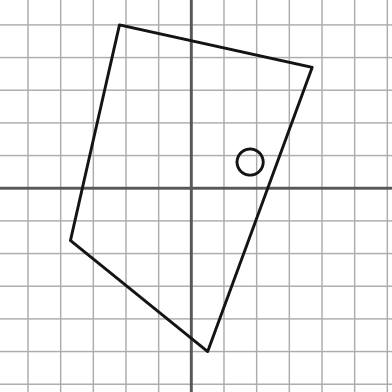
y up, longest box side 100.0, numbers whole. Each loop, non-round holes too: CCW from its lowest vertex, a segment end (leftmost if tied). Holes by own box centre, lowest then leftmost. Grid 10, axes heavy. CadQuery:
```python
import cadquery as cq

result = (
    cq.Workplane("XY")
    .moveTo(5.0, -50.0)
    .lineTo(37.0, 37.0)
    .lineTo(-22.0, 50.0)
    .lineTo(-37.0, -16.0)
    .close()
    .moveTo(18.0, 8.0)
    .circle(4.0)
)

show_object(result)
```